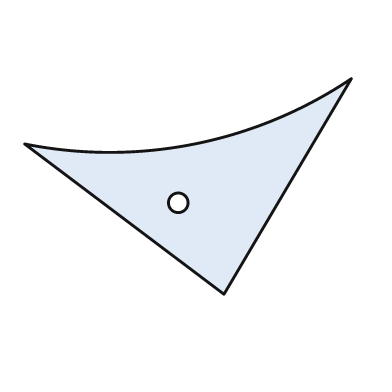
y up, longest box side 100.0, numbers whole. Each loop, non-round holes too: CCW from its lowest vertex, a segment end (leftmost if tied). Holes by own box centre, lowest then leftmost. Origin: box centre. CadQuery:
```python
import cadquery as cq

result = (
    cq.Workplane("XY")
    .moveTo(11.0, -33.0)
    .lineTo(50.0, 33.0)
    .threePointArc((2.0, 13.0), (-50.0, 13.0))
    .close()
    .moveTo(-3.0, -5.0)
    .circle(3.0)
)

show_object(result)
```